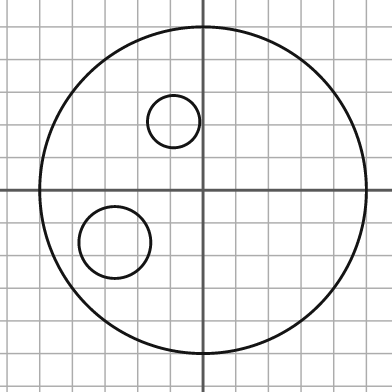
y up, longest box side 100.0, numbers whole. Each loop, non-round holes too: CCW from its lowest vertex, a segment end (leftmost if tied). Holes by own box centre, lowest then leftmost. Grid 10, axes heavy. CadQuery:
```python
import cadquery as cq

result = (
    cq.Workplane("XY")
    .moveTo(0.0, 0.0)
    .circle(50.0)
    .moveTo(-27.0, -16.0)
    .circle(11.0)
    .moveTo(-9.0, 21.0)
    .circle(8.0)
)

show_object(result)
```